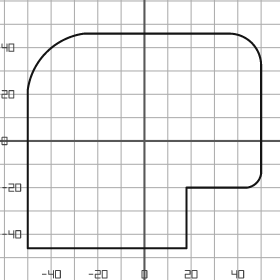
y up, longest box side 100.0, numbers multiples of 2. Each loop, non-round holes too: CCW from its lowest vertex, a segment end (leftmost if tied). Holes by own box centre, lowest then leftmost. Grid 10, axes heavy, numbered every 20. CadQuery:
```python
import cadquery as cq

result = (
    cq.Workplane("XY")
    .moveTo(-50.0, -46.0)
    .lineTo(18.0, -46.0)
    .lineTo(18.0, -20.0)
    .lineTo(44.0, -20.0)
    .threePointArc((48.0, -18.0), (50.0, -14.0))
    .lineTo(50.0, 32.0)
    .threePointArc((46.0, 42.0), (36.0, 46.0))
    .lineTo(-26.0, 46.0)
    .threePointArc((-42.0, 38.0), (-50.0, 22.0))
    .close()
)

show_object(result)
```